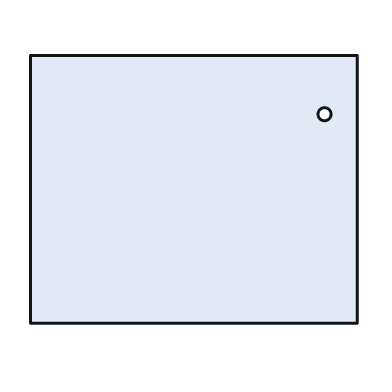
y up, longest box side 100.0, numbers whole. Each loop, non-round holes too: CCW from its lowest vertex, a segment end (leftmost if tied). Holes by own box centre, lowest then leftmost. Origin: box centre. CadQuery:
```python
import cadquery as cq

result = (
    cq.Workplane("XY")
    .moveTo(-50.0, -41.0)
    .lineTo(50.0, -41.0)
    .lineTo(50.0, 41.0)
    .lineTo(-50.0, 41.0)
    .close()
    .moveTo(40.0, 23.0)
    .circle(2.0)
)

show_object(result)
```